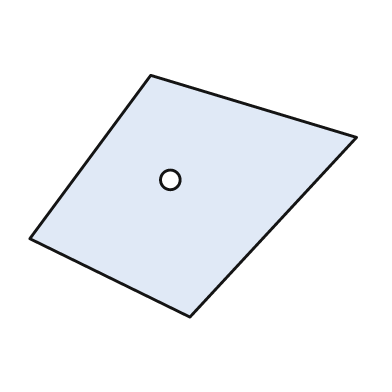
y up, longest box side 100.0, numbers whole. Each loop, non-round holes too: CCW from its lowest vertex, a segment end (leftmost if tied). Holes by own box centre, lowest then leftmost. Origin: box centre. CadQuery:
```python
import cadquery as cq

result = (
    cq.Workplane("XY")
    .moveTo(-1.0, -37.0)
    .lineTo(50.0, 18.0)
    .lineTo(-13.0, 37.0)
    .lineTo(-50.0, -13.0)
    .close()
    .moveTo(-7.0, 5.0)
    .circle(3.0)
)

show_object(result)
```